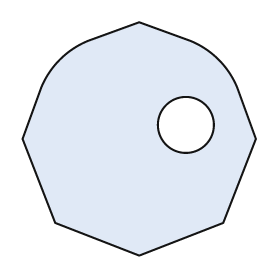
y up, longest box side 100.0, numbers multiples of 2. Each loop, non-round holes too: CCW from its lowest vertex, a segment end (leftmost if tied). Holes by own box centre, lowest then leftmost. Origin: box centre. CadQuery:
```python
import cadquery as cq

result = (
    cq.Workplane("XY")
    .moveTo(0.0, -50.0)
    .lineTo(36.0, -36.0)
    .lineTo(50.0, 0.0)
    .lineTo(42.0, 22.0)
    .threePointArc((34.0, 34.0), (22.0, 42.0))
    .lineTo(0.0, 50.0)
    .lineTo(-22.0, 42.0)
    .threePointArc((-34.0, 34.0), (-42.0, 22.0))
    .lineTo(-50.0, 0.0)
    .lineTo(-36.0, -36.0)
    .close()
    .moveTo(20.0, 6.0)
    .circle(12.0)
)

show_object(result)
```